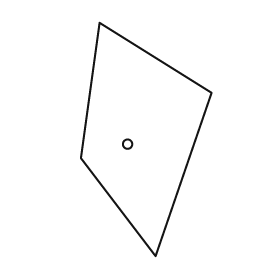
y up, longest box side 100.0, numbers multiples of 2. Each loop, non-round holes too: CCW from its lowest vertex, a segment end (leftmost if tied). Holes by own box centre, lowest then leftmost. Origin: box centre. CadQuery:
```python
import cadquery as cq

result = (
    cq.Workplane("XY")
    .moveTo(4.0, -50.0)
    .lineTo(28.0, 20.0)
    .lineTo(-20.0, 50.0)
    .lineTo(-28.0, -8.0)
    .close()
    .moveTo(-8.0, -2.0)
    .circle(2.0)
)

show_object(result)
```